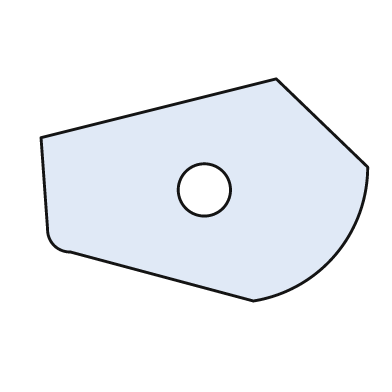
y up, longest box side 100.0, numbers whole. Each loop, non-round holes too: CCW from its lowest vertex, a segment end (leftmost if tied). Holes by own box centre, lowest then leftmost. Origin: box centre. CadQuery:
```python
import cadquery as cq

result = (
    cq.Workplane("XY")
    .moveTo(15.0, -34.0)
    .threePointArc((40.0, -20.0), (50.0, 7.0))
    .lineTo(22.0, 34.0)
    .lineTo(-50.0, 16.0)
    .lineTo(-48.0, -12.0)
    .threePointArc((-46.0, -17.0), (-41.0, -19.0))
    .close()
    .moveTo(0.0, 0.0)
    .circle(8.0)
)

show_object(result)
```